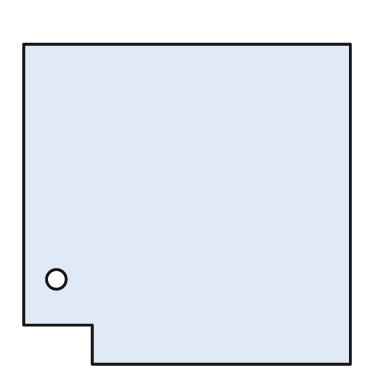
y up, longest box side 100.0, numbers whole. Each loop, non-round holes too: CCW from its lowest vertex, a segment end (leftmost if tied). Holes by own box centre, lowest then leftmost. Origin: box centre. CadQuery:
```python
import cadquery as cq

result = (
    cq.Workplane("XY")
    .moveTo(-29.0, -49.0)
    .lineTo(50.0, -49.0)
    .lineTo(50.0, 49.0)
    .lineTo(-50.0, 49.0)
    .lineTo(-50.0, -37.0)
    .lineTo(-29.0, -37.0)
    .close()
    .moveTo(-40.0, -23.0)
    .circle(3.0)
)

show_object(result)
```